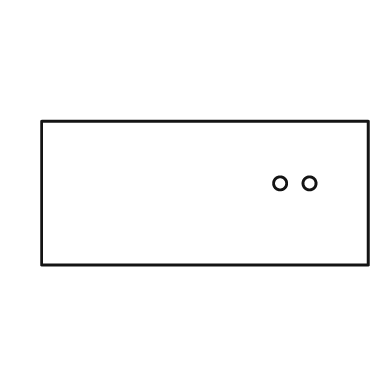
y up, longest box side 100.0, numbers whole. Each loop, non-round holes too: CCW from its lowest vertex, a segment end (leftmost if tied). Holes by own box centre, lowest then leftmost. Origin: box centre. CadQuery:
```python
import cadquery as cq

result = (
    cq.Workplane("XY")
    .moveTo(-50.0, -22.0)
    .lineTo(50.0, -22.0)
    .lineTo(50.0, 22.0)
    .lineTo(-50.0, 22.0)
    .close()
    .moveTo(23.0, 3.0)
    .circle(2.0)
    .moveTo(32.0, 3.0)
    .circle(2.0)
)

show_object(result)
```